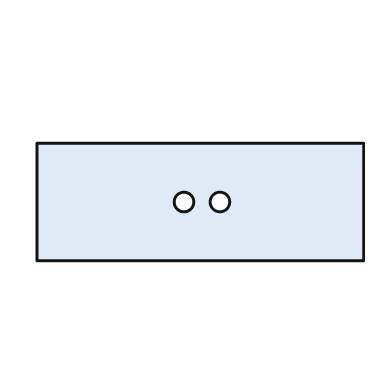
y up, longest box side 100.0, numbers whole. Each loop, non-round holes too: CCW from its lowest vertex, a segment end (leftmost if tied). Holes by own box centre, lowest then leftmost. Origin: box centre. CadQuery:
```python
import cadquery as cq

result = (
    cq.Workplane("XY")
    .moveTo(-50.0, -18.0)
    .lineTo(50.0, -18.0)
    .lineTo(50.0, 18.0)
    .lineTo(-50.0, 18.0)
    .close()
    .moveTo(-5.0, 0.0)
    .circle(3.0)
    .moveTo(6.0, 0.0)
    .circle(3.0)
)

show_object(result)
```